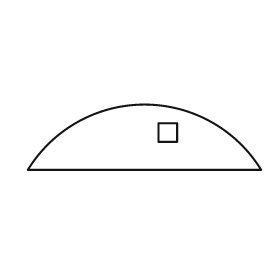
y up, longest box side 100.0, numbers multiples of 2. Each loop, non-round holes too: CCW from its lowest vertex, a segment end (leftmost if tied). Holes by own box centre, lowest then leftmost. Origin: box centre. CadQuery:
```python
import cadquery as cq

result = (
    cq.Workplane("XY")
    .moveTo(-50.0, -14.0)
    .lineTo(50.0, -14.0)
    .threePointArc((0.0, 14.0), (-50.0, -14.0))
    .close()
    .moveTo(6.0, -2.0)
    .lineTo(14.0, -2.0)
    .lineTo(14.0, 6.0)
    .lineTo(6.0, 6.0)
    .close()
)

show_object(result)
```